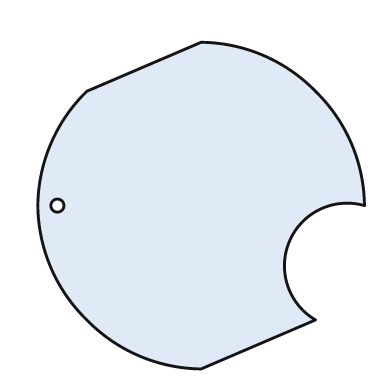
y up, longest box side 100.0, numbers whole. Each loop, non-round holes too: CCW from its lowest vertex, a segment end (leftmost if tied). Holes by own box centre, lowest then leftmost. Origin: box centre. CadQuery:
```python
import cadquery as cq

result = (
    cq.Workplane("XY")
    .moveTo(0.0, -50.0)
    .lineTo(35.0, -35.0)
    .threePointArc((27.0, -11.0), (50.0, 0.0))
    .threePointArc((46.0, 19.0), (35.0, 35.0))
    .threePointArc((19.0, 46.0), (0.0, 50.0))
    .lineTo(-35.0, 35.0)
    .threePointArc((-46.0, 19.0), (-50.0, 0.0))
    .threePointArc((-46.0, -19.0), (-35.0, -35.0))
    .threePointArc((-19.0, -46.0), (0.0, -50.0))
    .close()
    .moveTo(-44.0, 0.0)
    .circle(2.0)
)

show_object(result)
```